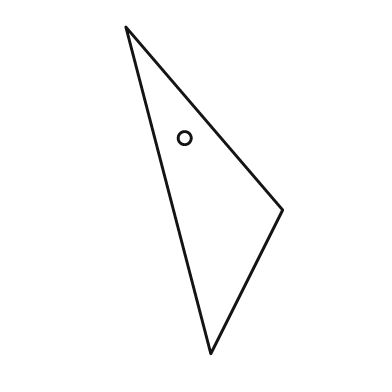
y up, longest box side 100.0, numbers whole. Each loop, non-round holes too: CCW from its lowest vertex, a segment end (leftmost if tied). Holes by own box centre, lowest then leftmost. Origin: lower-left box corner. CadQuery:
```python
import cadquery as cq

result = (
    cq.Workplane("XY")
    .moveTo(26.0, 0.0)
    .lineTo(48.0, 44.0)
    .lineTo(0.0, 100.0)
    .close()
    .moveTo(18.0, 66.0)
    .circle(2.0)
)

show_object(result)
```